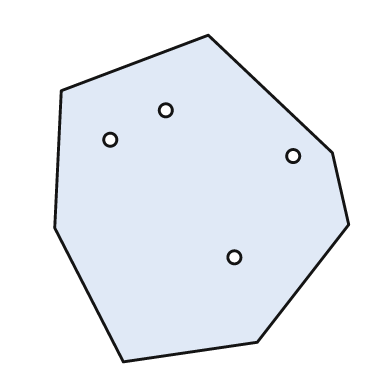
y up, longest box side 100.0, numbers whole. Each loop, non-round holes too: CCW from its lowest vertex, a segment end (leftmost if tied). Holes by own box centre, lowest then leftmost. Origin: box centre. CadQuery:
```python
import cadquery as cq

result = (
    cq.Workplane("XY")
    .moveTo(-24.0, -50.0)
    .lineTo(17.0, -44.0)
    .lineTo(45.0, -8.0)
    .lineTo(40.0, 14.0)
    .lineTo(2.0, 50.0)
    .lineTo(-43.0, 33.0)
    .lineTo(-45.0, -9.0)
    .close()
    .moveTo(10.0, -18.0)
    .circle(2.0)
    .moveTo(28.0, 13.0)
    .circle(2.0)
    .moveTo(-28.0, 18.0)
    .circle(2.0)
    .moveTo(-11.0, 27.0)
    .circle(2.0)
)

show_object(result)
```